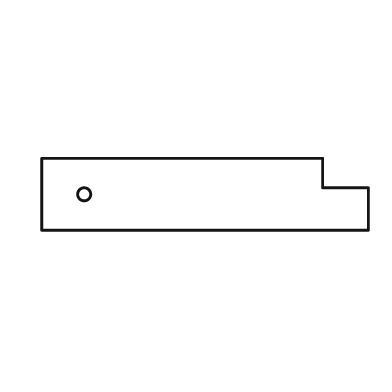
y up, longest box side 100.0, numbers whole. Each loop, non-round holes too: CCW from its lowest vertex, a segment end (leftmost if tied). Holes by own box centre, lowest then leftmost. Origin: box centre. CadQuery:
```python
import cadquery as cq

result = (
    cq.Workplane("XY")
    .moveTo(-50.0, -11.0)
    .lineTo(50.0, -11.0)
    .lineTo(50.0, 2.0)
    .lineTo(36.0, 2.0)
    .lineTo(36.0, 11.0)
    .lineTo(-50.0, 11.0)
    .close()
    .moveTo(-37.0, 0.0)
    .circle(2.0)
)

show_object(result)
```